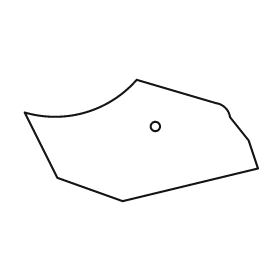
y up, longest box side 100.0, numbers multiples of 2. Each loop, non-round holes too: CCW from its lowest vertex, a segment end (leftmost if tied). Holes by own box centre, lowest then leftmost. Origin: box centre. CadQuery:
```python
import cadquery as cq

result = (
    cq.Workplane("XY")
    .moveTo(-8.0, -26.0)
    .lineTo(50.0, -12.0)
    .lineTo(46.0, 0.0)
    .lineTo(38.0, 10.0)
    .threePointArc((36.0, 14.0), (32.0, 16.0))
    .lineTo(-2.0, 26.0)
    .threePointArc((-24.0, 12.0), (-50.0, 12.0))
    .lineTo(-36.0, -16.0)
    .close()
    .moveTo(6.0, 6.0)
    .circle(2.0)
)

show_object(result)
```